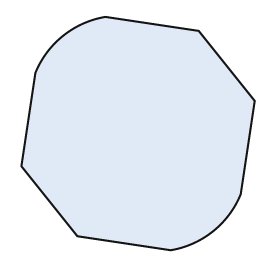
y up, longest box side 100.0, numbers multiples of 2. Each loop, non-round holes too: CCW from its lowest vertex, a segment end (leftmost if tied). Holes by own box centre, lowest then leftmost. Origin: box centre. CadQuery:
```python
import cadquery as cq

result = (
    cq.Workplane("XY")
    .moveTo(14.0, -50.0)
    .threePointArc((32.0, -42.0), (44.0, -26.0))
    .lineTo(50.0, 14.0)
    .lineTo(26.0, 44.0)
    .lineTo(-14.0, 50.0)
    .threePointArc((-32.0, 42.0), (-44.0, 26.0))
    .lineTo(-50.0, -14.0)
    .lineTo(-26.0, -44.0)
    .close()
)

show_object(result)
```